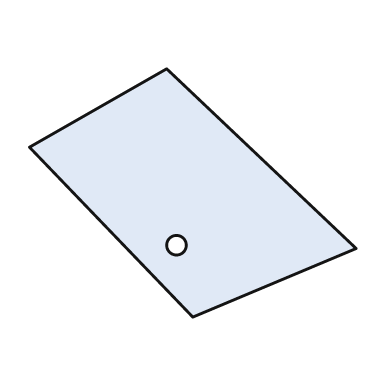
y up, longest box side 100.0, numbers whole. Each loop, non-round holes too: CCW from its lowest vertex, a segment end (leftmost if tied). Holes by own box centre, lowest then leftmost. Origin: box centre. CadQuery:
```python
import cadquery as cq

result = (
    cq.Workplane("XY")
    .moveTo(0.0, -38.0)
    .lineTo(50.0, -17.0)
    .lineTo(-8.0, 38.0)
    .lineTo(-50.0, 14.0)
    .close()
    .moveTo(-5.0, -16.0)
    .circle(3.0)
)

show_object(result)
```